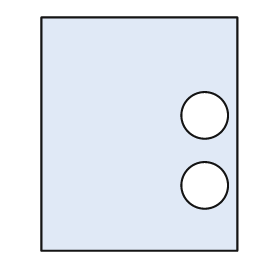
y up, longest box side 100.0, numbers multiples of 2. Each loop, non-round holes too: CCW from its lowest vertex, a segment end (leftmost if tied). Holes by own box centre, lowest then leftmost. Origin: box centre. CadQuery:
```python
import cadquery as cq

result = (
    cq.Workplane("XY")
    .moveTo(-42.0, -50.0)
    .lineTo(42.0, -50.0)
    .lineTo(42.0, 50.0)
    .lineTo(-42.0, 50.0)
    .close()
    .moveTo(28.0, -22.0)
    .circle(10.0)
    .moveTo(28.0, 8.0)
    .circle(10.0)
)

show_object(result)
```